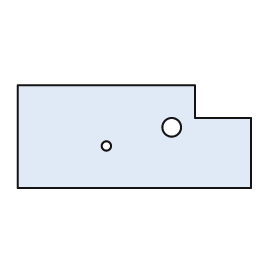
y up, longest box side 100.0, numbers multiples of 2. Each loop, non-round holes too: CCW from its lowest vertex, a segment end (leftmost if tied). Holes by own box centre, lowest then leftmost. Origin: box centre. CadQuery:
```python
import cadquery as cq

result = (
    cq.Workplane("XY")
    .moveTo(-50.0, -22.0)
    .lineTo(50.0, -22.0)
    .lineTo(50.0, 8.0)
    .lineTo(26.0, 8.0)
    .lineTo(26.0, 22.0)
    .lineTo(-50.0, 22.0)
    .close()
    .moveTo(-12.0, -4.0)
    .circle(2.0)
    .moveTo(16.0, 4.0)
    .circle(4.0)
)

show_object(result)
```